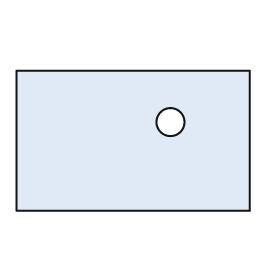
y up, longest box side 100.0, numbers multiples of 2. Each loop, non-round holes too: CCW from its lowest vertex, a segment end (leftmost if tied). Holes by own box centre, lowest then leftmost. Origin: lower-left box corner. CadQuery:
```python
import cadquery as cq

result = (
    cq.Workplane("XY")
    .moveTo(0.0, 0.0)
    .lineTo(100.0, 0.0)
    .lineTo(100.0, 60.0)
    .lineTo(0.0, 60.0)
    .close()
    .moveTo(66.0, 38.0)
    .circle(6.0)
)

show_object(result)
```